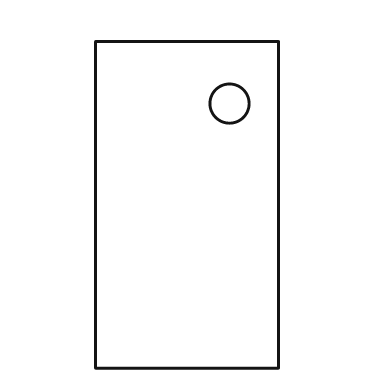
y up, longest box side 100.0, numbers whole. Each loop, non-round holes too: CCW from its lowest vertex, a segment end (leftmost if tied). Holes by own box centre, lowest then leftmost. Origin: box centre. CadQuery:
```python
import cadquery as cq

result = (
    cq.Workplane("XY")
    .moveTo(-28.0, -50.0)
    .lineTo(28.0, -50.0)
    .lineTo(28.0, 50.0)
    .lineTo(-28.0, 50.0)
    .close()
    .moveTo(13.0, 31.0)
    .circle(6.0)
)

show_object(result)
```